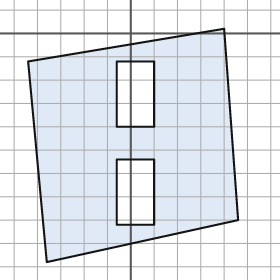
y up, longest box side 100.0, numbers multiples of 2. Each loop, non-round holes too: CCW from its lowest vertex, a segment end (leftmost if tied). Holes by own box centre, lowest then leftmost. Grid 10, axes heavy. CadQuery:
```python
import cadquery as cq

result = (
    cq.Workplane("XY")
    .moveTo(-36.0, -98.0)
    .lineTo(46.0, -80.0)
    .lineTo(40.0, 2.0)
    .lineTo(-44.0, -12.0)
    .close()
    .moveTo(-6.0, -82.0)
    .lineTo(10.0, -82.0)
    .lineTo(10.0, -54.0)
    .lineTo(-6.0, -54.0)
    .close()
    .moveTo(-6.0, -40.0)
    .lineTo(10.0, -40.0)
    .lineTo(10.0, -12.0)
    .lineTo(-6.0, -12.0)
    .close()
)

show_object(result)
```